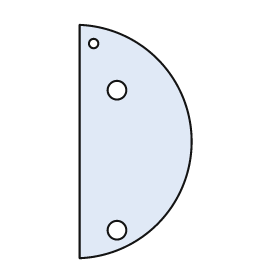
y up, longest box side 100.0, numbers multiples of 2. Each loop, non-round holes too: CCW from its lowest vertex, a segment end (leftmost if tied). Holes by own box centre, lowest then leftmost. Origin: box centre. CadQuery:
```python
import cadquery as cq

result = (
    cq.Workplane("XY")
    .moveTo(-24.0, -50.0)
    .threePointArc((24.0, 0.0), (-24.0, 50.0))
    .close()
    .moveTo(-8.0, -38.0)
    .circle(4.0)
    .moveTo(-8.0, 22.0)
    .circle(4.0)
    .moveTo(-18.0, 42.0)
    .circle(2.0)
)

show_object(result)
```